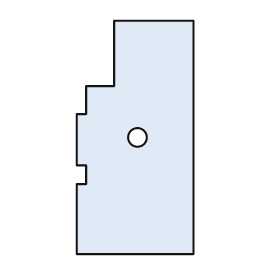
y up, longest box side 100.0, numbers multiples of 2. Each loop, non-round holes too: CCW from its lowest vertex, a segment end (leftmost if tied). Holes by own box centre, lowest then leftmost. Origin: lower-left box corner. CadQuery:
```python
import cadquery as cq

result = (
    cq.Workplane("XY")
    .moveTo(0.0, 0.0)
    .lineTo(50.0, 0.0)
    .lineTo(50.0, 100.0)
    .lineTo(16.0, 100.0)
    .lineTo(16.0, 72.0)
    .lineTo(4.0, 72.0)
    .lineTo(4.0, 60.0)
    .lineTo(0.0, 60.0)
    .lineTo(0.0, 38.0)
    .lineTo(4.0, 38.0)
    .lineTo(4.0, 30.0)
    .lineTo(0.0, 30.0)
    .close()
    .moveTo(26.0, 50.0)
    .circle(4.0)
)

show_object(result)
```